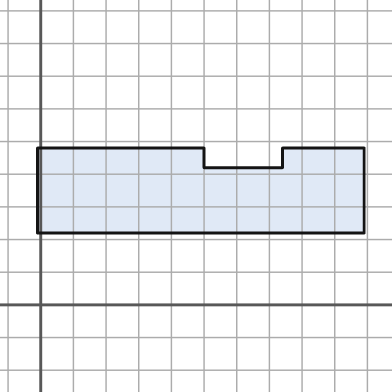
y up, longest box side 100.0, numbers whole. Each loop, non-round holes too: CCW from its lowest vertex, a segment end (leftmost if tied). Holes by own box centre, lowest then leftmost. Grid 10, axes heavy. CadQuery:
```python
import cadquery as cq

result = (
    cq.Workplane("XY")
    .moveTo(-1.0, 22.0)
    .lineTo(99.0, 22.0)
    .lineTo(99.0, 48.0)
    .lineTo(74.0, 48.0)
    .lineTo(74.0, 42.0)
    .lineTo(50.0, 42.0)
    .lineTo(50.0, 48.0)
    .lineTo(-1.0, 48.0)
    .close()
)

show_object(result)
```